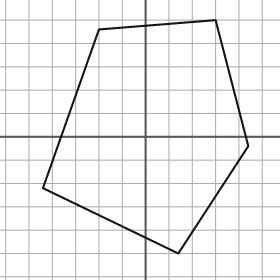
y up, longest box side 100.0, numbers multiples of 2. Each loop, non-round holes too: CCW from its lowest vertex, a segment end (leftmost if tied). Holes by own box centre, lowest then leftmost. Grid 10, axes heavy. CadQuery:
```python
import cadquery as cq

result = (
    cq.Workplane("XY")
    .moveTo(14.0, -50.0)
    .lineTo(44.0, -4.0)
    .lineTo(30.0, 50.0)
    .lineTo(-20.0, 46.0)
    .lineTo(-44.0, -22.0)
    .close()
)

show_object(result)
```